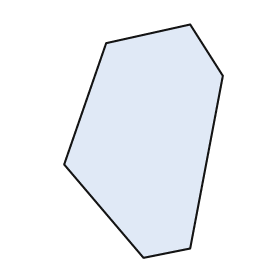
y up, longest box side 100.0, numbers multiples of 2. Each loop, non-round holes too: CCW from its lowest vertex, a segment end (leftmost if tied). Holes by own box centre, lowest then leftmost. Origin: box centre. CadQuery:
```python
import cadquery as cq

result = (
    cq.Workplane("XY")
    .moveTo(0.0, -50.0)
    .lineTo(20.0, -46.0)
    .lineTo(34.0, 28.0)
    .lineTo(20.0, 50.0)
    .lineTo(-16.0, 42.0)
    .lineTo(-34.0, -10.0)
    .close()
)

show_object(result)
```